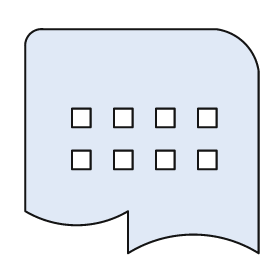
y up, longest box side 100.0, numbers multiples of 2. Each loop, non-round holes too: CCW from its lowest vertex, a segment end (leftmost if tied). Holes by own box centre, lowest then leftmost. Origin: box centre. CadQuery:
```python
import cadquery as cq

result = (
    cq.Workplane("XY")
    .moveTo(-6.0, -48.0)
    .threePointArc((22.0, -40.0), (50.0, -48.0))
    .lineTo(50.0, 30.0)
    .threePointArc((44.0, 42.0), (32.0, 48.0))
    .lineTo(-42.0, 48.0)
    .threePointArc((-48.0, 46.0), (-50.0, 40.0))
    .lineTo(-50.0, -30.0)
    .threePointArc((-28.0, -36.0), (-6.0, -30.0))
    .close()
    .moveTo(-30.0, -12.0)
    .lineTo(-22.0, -12.0)
    .lineTo(-22.0, -4.0)
    .lineTo(-30.0, -4.0)
    .close()
    .moveTo(-12.0, -12.0)
    .lineTo(-4.0, -12.0)
    .lineTo(-4.0, -4.0)
    .lineTo(-12.0, -4.0)
    .close()
    .moveTo(6.0, -12.0)
    .lineTo(14.0, -12.0)
    .lineTo(14.0, -4.0)
    .lineTo(6.0, -4.0)
    .close()
    .moveTo(24.0, -12.0)
    .lineTo(32.0, -12.0)
    .lineTo(32.0, -4.0)
    .lineTo(24.0, -4.0)
    .close()
    .moveTo(-30.0, 6.0)
    .lineTo(-22.0, 6.0)
    .lineTo(-22.0, 14.0)
    .lineTo(-30.0, 14.0)
    .close()
    .moveTo(-12.0, 6.0)
    .lineTo(-4.0, 6.0)
    .lineTo(-4.0, 14.0)
    .lineTo(-12.0, 14.0)
    .close()
    .moveTo(6.0, 6.0)
    .lineTo(14.0, 6.0)
    .lineTo(14.0, 14.0)
    .lineTo(6.0, 14.0)
    .close()
    .moveTo(24.0, 6.0)
    .lineTo(32.0, 6.0)
    .lineTo(32.0, 14.0)
    .lineTo(24.0, 14.0)
    .close()
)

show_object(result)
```